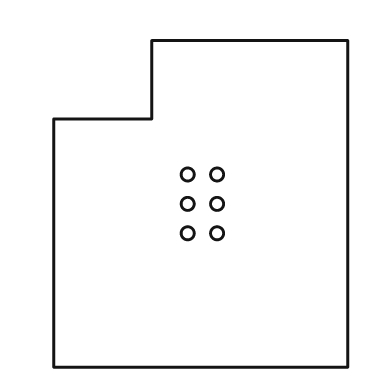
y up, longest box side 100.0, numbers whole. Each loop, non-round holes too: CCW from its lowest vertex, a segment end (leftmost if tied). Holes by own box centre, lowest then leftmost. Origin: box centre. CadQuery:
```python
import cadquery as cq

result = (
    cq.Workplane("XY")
    .moveTo(-45.0, -50.0)
    .lineTo(45.0, -50.0)
    .lineTo(45.0, 50.0)
    .lineTo(-15.0, 50.0)
    .lineTo(-15.0, 26.0)
    .lineTo(-45.0, 26.0)
    .close()
    .moveTo(-4.0, -9.0)
    .circle(2.0)
    .moveTo(5.0, -9.0)
    .circle(2.0)
    .moveTo(-4.0, 0.0)
    .circle(2.0)
    .moveTo(5.0, 0.0)
    .circle(2.0)
    .moveTo(-4.0, 9.0)
    .circle(2.0)
    .moveTo(5.0, 9.0)
    .circle(2.0)
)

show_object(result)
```